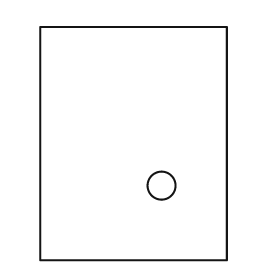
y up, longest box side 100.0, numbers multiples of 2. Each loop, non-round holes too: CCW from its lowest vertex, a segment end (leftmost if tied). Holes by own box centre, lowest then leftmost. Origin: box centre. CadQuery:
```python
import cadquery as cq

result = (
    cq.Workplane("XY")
    .moveTo(-40.0, -50.0)
    .lineTo(40.0, -50.0)
    .lineTo(40.0, 50.0)
    .lineTo(-40.0, 50.0)
    .close()
    .moveTo(12.0, -18.0)
    .circle(6.0)
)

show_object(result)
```